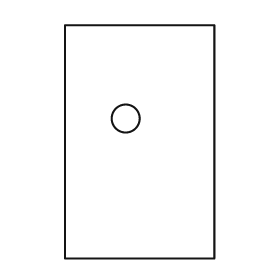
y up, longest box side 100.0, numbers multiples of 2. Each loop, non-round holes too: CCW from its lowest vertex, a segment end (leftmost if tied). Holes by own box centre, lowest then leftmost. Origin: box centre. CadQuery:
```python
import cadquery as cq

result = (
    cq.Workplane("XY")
    .moveTo(-32.0, -50.0)
    .lineTo(32.0, -50.0)
    .lineTo(32.0, 50.0)
    .lineTo(-32.0, 50.0)
    .close()
    .moveTo(-6.0, 10.0)
    .circle(6.0)
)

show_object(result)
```